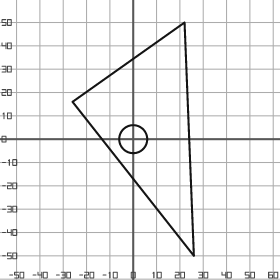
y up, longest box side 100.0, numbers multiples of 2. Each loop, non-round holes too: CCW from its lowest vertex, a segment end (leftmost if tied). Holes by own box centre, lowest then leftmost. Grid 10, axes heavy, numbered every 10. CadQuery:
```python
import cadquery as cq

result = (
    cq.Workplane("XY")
    .moveTo(26.0, -50.0)
    .lineTo(22.0, 50.0)
    .lineTo(-26.0, 16.0)
    .close()
    .moveTo(0.0, 0.0)
    .circle(6.0)
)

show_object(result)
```